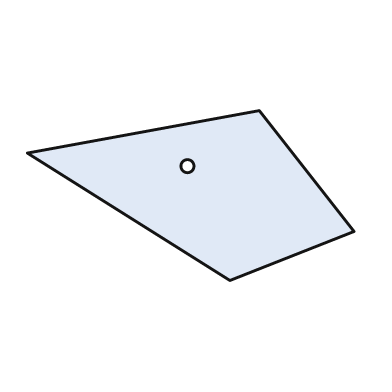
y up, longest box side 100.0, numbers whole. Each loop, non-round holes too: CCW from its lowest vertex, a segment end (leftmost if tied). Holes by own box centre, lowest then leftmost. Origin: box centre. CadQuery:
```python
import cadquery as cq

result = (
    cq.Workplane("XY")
    .moveTo(12.0, -26.0)
    .lineTo(50.0, -11.0)
    .lineTo(21.0, 26.0)
    .lineTo(-50.0, 13.0)
    .close()
    .moveTo(-1.0, 9.0)
    .circle(2.0)
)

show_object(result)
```